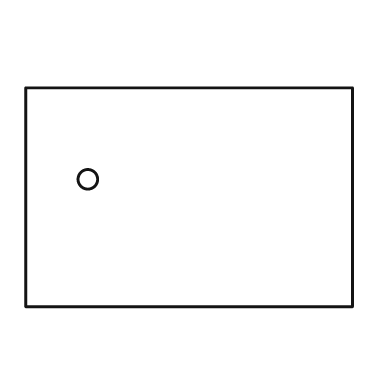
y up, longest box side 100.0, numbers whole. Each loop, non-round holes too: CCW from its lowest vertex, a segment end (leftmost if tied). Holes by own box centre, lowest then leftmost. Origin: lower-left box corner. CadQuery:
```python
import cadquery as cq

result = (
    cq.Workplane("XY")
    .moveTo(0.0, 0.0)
    .lineTo(100.0, 0.0)
    .lineTo(100.0, 67.0)
    .lineTo(0.0, 67.0)
    .close()
    .moveTo(19.0, 39.0)
    .circle(3.0)
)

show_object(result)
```